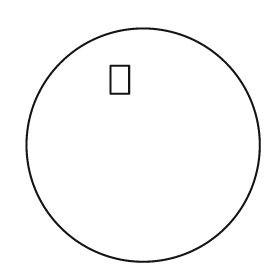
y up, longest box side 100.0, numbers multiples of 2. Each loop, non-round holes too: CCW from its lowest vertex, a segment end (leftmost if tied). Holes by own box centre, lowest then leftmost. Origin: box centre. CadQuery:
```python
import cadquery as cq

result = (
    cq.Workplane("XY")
    .moveTo(0.0, 0.0)
    .circle(50.0)
    .moveTo(-14.0, 22.0)
    .lineTo(-6.0, 22.0)
    .lineTo(-6.0, 34.0)
    .lineTo(-14.0, 34.0)
    .close()
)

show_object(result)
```